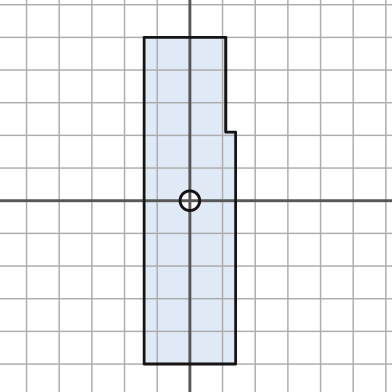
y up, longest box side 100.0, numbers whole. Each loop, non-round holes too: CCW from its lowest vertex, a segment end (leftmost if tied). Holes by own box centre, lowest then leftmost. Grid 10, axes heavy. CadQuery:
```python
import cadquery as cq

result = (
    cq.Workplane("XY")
    .moveTo(-14.0, -50.0)
    .lineTo(14.0, -50.0)
    .lineTo(14.0, 21.0)
    .lineTo(11.0, 21.0)
    .lineTo(11.0, 50.0)
    .lineTo(-14.0, 50.0)
    .close()
    .moveTo(0.0, 0.0)
    .circle(3.0)
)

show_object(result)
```